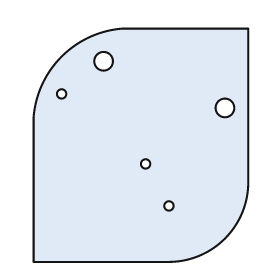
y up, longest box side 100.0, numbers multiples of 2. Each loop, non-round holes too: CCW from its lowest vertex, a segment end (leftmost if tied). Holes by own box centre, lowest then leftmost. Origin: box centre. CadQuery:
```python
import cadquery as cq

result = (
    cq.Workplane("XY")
    .moveTo(-46.0, -50.0)
    .lineTo(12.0, -50.0)
    .threePointArc((36.0, -40.0), (46.0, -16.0))
    .lineTo(46.0, 50.0)
    .lineTo(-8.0, 50.0)
    .threePointArc((-34.0, 38.0), (-46.0, 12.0))
    .close()
    .moveTo(12.0, -26.0)
    .circle(2.0)
    .moveTo(2.0, -8.0)
    .circle(2.0)
    .moveTo(36.0, 16.0)
    .circle(4.0)
    .moveTo(-34.0, 22.0)
    .circle(2.0)
    .moveTo(-16.0, 36.0)
    .circle(4.0)
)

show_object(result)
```